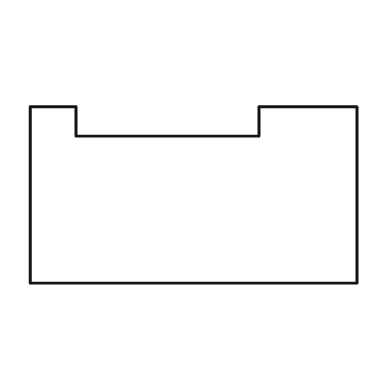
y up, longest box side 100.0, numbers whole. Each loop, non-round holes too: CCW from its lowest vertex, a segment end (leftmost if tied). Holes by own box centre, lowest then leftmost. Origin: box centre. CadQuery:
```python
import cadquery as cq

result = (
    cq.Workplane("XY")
    .moveTo(-50.0, -27.0)
    .lineTo(50.0, -27.0)
    .lineTo(50.0, 27.0)
    .lineTo(20.0, 27.0)
    .lineTo(20.0, 18.0)
    .lineTo(-36.0, 18.0)
    .lineTo(-36.0, 27.0)
    .lineTo(-50.0, 27.0)
    .close()
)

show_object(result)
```